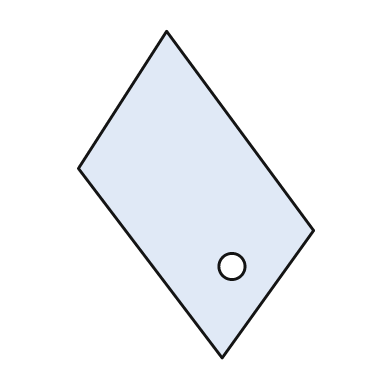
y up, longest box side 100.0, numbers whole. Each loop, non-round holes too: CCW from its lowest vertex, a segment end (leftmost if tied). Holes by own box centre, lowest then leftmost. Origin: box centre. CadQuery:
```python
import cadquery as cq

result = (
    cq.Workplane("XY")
    .moveTo(8.0, -50.0)
    .lineTo(36.0, -11.0)
    .lineTo(-9.0, 50.0)
    .lineTo(-36.0, 8.0)
    .close()
    .moveTo(11.0, -22.0)
    .circle(4.0)
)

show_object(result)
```